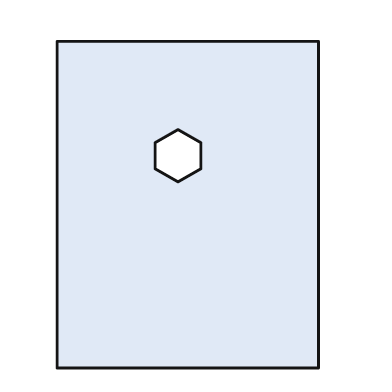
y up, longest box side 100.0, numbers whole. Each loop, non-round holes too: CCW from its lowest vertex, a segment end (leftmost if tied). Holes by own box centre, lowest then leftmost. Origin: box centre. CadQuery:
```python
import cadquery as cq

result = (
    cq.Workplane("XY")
    .moveTo(-40.0, -50.0)
    .lineTo(40.0, -50.0)
    .lineTo(40.0, 50.0)
    .lineTo(-40.0, 50.0)
    .close()
    .moveTo(-3.0, 7.0)
    .lineTo(4.0, 11.0)
    .lineTo(4.0, 19.0)
    .lineTo(-3.0, 23.0)
    .lineTo(-10.0, 19.0)
    .lineTo(-10.0, 11.0)
    .close()
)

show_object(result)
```